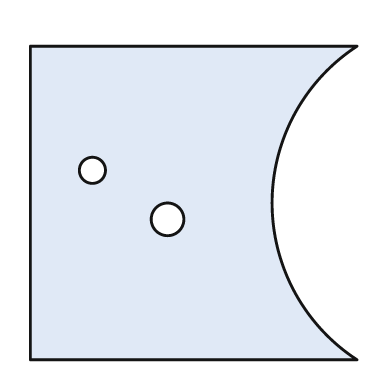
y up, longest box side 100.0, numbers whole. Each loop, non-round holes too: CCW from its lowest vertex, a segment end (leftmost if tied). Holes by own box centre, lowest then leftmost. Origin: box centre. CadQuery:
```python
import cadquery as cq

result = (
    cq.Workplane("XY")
    .moveTo(-50.0, -48.0)
    .lineTo(50.0, -48.0)
    .threePointArc((24.0, 0.0), (50.0, 48.0))
    .lineTo(-50.0, 48.0)
    .close()
    .moveTo(-8.0, -5.0)
    .circle(5.0)
    .moveTo(-31.0, 10.0)
    .circle(4.0)
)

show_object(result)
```